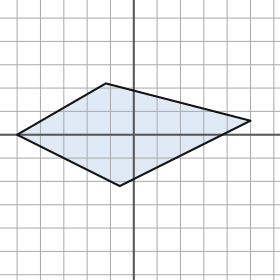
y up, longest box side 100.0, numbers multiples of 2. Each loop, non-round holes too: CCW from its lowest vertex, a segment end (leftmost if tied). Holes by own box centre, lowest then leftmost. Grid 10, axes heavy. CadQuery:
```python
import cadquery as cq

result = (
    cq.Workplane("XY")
    .moveTo(-6.0, -22.0)
    .lineTo(50.0, 6.0)
    .lineTo(-12.0, 22.0)
    .lineTo(-50.0, 0.0)
    .close()
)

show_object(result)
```